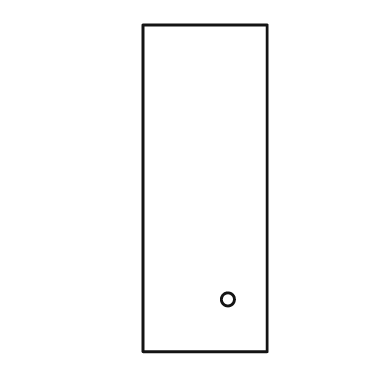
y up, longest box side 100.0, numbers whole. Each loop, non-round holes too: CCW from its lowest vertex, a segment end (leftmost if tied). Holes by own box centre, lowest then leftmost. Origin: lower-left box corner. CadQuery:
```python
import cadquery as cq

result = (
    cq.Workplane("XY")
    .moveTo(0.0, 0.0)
    .lineTo(38.0, 0.0)
    .lineTo(38.0, 100.0)
    .lineTo(0.0, 100.0)
    .close()
    .moveTo(26.0, 16.0)
    .circle(2.0)
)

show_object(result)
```